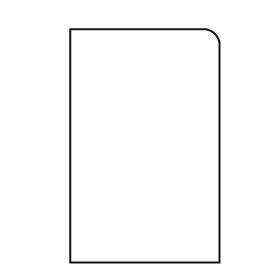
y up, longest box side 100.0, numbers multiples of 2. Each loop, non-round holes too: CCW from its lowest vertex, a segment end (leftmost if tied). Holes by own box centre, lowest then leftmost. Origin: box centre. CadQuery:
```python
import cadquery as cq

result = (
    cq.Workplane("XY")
    .moveTo(-32.0, -50.0)
    .lineTo(32.0, -50.0)
    .lineTo(32.0, 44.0)
    .threePointArc((30.0, 48.0), (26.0, 50.0))
    .lineTo(-32.0, 50.0)
    .close()
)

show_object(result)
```